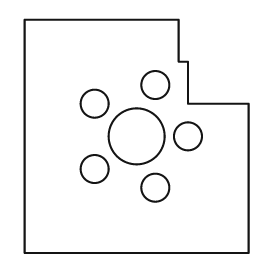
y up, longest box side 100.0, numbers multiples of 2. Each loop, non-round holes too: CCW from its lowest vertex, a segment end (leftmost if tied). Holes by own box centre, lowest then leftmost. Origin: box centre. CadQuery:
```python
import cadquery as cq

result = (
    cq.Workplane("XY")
    .moveTo(-48.0, -50.0)
    .lineTo(48.0, -50.0)
    .lineTo(48.0, 14.0)
    .lineTo(22.0, 14.0)
    .lineTo(22.0, 32.0)
    .lineTo(18.0, 32.0)
    .lineTo(18.0, 50.0)
    .lineTo(-48.0, 50.0)
    .close()
    .moveTo(8.0, -22.0)
    .circle(6.0)
    .moveTo(-18.0, -14.0)
    .circle(6.0)
    .moveTo(0.0, 0.0)
    .circle(12.0)
    .moveTo(22.0, 0.0)
    .circle(6.0)
    .moveTo(-18.0, 14.0)
    .circle(6.0)
    .moveTo(8.0, 22.0)
    .circle(6.0)
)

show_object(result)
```